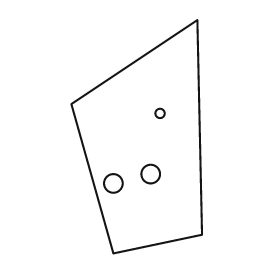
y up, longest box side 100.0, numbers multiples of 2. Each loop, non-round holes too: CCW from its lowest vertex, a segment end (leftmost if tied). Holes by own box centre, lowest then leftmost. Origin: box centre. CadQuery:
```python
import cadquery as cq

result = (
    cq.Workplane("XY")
    .moveTo(-10.0, -50.0)
    .lineTo(28.0, -42.0)
    .lineTo(26.0, 50.0)
    .lineTo(-28.0, 14.0)
    .close()
    .moveTo(-10.0, -20.0)
    .circle(4.0)
    .moveTo(6.0, -16.0)
    .circle(4.0)
    .moveTo(10.0, 10.0)
    .circle(2.0)
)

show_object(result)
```